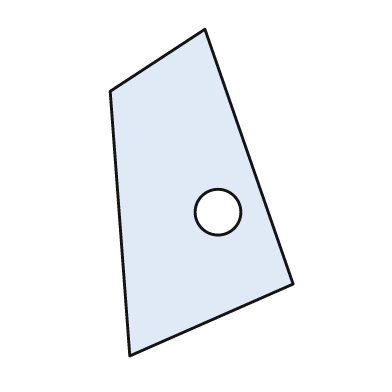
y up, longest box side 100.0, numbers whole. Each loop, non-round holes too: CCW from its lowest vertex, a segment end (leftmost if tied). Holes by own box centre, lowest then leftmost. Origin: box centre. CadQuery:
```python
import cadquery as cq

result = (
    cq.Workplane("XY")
    .moveTo(-22.0, -50.0)
    .lineTo(28.0, -28.0)
    .lineTo(1.0, 50.0)
    .lineTo(-28.0, 31.0)
    .close()
    .moveTo(5.0, -6.0)
    .circle(7.0)
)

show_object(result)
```